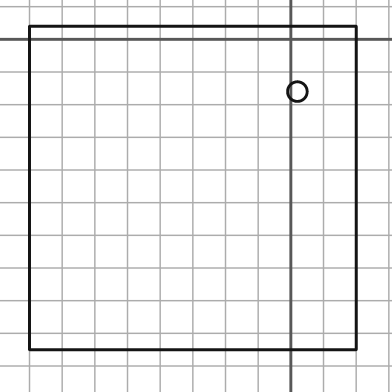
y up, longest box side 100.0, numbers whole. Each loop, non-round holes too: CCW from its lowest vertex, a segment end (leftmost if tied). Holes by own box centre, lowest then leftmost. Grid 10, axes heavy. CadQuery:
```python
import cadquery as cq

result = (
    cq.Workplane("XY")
    .moveTo(-80.0, -95.0)
    .lineTo(20.0, -95.0)
    .lineTo(20.0, 4.0)
    .lineTo(-80.0, 4.0)
    .close()
    .moveTo(2.0, -16.0)
    .circle(3.0)
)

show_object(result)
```